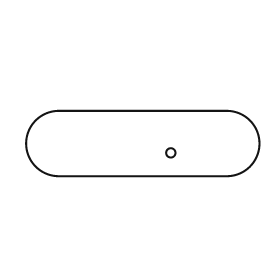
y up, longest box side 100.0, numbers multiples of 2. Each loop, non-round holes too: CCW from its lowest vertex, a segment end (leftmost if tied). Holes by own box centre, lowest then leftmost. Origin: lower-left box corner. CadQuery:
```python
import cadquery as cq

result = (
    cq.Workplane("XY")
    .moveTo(14.0, 0.0)
    .lineTo(86.0, 0.0)
    .threePointArc((100.0, 14.0), (86.0, 28.0))
    .lineTo(14.0, 28.0)
    .threePointArc((0.0, 14.0), (14.0, 0.0))
    .close()
    .moveTo(62.0, 10.0)
    .circle(2.0)
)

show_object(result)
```